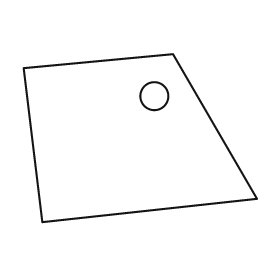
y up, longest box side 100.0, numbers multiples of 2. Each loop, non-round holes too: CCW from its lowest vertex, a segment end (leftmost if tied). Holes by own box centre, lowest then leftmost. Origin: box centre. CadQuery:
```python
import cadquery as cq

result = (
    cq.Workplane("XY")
    .moveTo(-42.0, -36.0)
    .lineTo(50.0, -26.0)
    .lineTo(14.0, 36.0)
    .lineTo(-50.0, 30.0)
    .close()
    .moveTo(6.0, 18.0)
    .circle(6.0)
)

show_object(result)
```